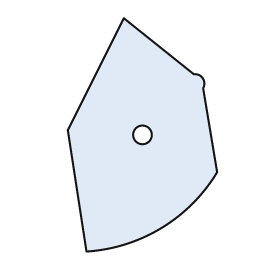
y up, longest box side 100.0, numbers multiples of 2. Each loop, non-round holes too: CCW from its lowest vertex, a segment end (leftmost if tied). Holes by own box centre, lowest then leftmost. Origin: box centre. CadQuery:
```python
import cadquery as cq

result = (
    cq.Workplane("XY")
    .moveTo(-24.0, -50.0)
    .threePointArc((8.0, -40.0), (32.0, -16.0))
    .lineTo(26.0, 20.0)
    .threePointArc((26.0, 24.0), (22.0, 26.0))
    .lineTo(-8.0, 50.0)
    .lineTo(-32.0, 2.0)
    .close()
    .moveTo(0.0, 0.0)
    .circle(4.0)
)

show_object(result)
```